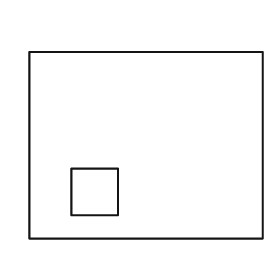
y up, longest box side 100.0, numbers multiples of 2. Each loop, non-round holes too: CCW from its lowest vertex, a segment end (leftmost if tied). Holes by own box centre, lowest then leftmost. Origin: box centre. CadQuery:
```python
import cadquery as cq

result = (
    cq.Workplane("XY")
    .moveTo(-50.0, -40.0)
    .lineTo(50.0, -40.0)
    .lineTo(50.0, 40.0)
    .lineTo(-50.0, 40.0)
    .close()
    .moveTo(-32.0, -30.0)
    .lineTo(-12.0, -30.0)
    .lineTo(-12.0, -10.0)
    .lineTo(-32.0, -10.0)
    .close()
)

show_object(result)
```